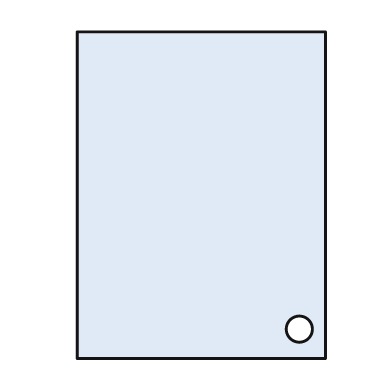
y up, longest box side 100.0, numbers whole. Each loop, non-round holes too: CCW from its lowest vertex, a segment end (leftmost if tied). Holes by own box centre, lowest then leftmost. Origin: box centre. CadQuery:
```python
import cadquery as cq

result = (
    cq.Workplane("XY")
    .moveTo(-38.0, -50.0)
    .lineTo(38.0, -50.0)
    .lineTo(38.0, 50.0)
    .lineTo(-38.0, 50.0)
    .close()
    .moveTo(30.0, -41.0)
    .circle(4.0)
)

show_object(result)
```